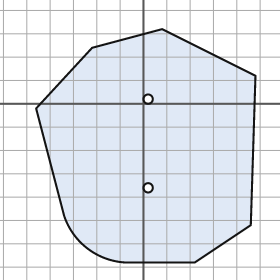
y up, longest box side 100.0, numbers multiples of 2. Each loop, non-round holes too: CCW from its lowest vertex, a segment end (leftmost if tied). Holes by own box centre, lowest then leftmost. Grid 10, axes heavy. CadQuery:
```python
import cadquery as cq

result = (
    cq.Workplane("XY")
    .moveTo(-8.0, -68.0)
    .lineTo(22.0, -68.0)
    .lineTo(46.0, -52.0)
    .lineTo(48.0, 12.0)
    .lineTo(8.0, 32.0)
    .lineTo(-22.0, 24.0)
    .lineTo(-46.0, -2.0)
    .lineTo(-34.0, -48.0)
    .threePointArc((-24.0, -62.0), (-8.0, -68.0))
    .close()
    .moveTo(2.0, -36.0)
    .circle(2.0)
    .moveTo(2.0, 2.0)
    .circle(2.0)
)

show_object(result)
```